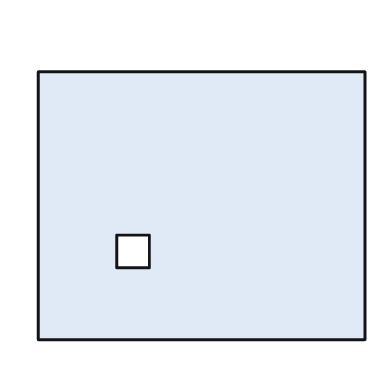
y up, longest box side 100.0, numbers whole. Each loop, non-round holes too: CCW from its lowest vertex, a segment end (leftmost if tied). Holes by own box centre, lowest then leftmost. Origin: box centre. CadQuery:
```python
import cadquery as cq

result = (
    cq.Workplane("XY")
    .moveTo(-50.0, -41.0)
    .lineTo(50.0, -41.0)
    .lineTo(50.0, 41.0)
    .lineTo(-50.0, 41.0)
    .close()
    .moveTo(-26.0, -19.0)
    .lineTo(-16.0, -19.0)
    .lineTo(-16.0, -9.0)
    .lineTo(-26.0, -9.0)
    .close()
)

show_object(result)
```